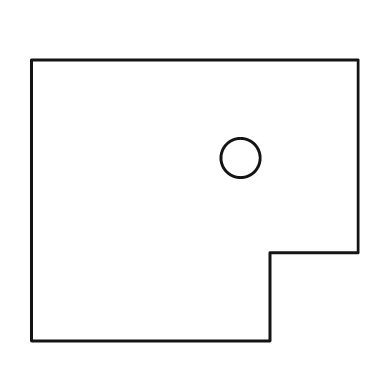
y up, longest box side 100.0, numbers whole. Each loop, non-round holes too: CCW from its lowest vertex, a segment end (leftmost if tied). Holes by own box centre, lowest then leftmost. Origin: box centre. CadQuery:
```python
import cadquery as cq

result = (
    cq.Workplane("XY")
    .moveTo(-50.0, -43.0)
    .lineTo(23.0, -43.0)
    .lineTo(23.0, -16.0)
    .lineTo(50.0, -16.0)
    .lineTo(50.0, 43.0)
    .lineTo(-50.0, 43.0)
    .close()
    .moveTo(14.0, 13.0)
    .circle(6.0)
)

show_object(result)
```